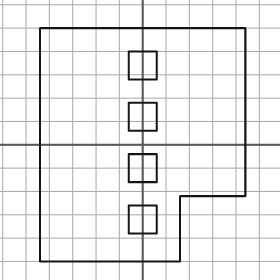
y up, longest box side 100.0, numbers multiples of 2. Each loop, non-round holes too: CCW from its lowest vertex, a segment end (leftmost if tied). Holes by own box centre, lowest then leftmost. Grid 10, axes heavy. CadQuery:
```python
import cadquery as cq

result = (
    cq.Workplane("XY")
    .moveTo(-44.0, -50.0)
    .lineTo(16.0, -50.0)
    .lineTo(16.0, -22.0)
    .lineTo(44.0, -22.0)
    .lineTo(44.0, 50.0)
    .lineTo(-44.0, 50.0)
    .close()
    .moveTo(-6.0, -38.0)
    .lineTo(6.0, -38.0)
    .lineTo(6.0, -26.0)
    .lineTo(-6.0, -26.0)
    .close()
    .moveTo(-6.0, -16.0)
    .lineTo(6.0, -16.0)
    .lineTo(6.0, -4.0)
    .lineTo(-6.0, -4.0)
    .close()
    .moveTo(-6.0, 6.0)
    .lineTo(6.0, 6.0)
    .lineTo(6.0, 18.0)
    .lineTo(-6.0, 18.0)
    .close()
    .moveTo(-6.0, 28.0)
    .lineTo(6.0, 28.0)
    .lineTo(6.0, 40.0)
    .lineTo(-6.0, 40.0)
    .close()
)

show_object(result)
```